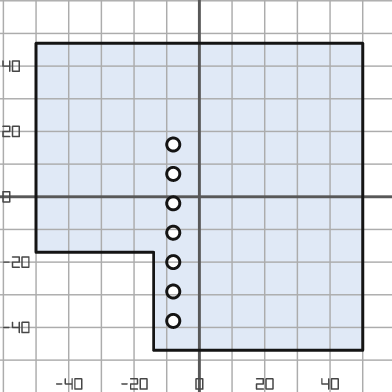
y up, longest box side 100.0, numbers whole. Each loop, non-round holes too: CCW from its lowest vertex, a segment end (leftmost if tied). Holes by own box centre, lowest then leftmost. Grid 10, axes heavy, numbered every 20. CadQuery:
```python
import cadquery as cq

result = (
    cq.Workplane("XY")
    .moveTo(-14.0, -47.0)
    .lineTo(50.0, -47.0)
    .lineTo(50.0, 47.0)
    .lineTo(-50.0, 47.0)
    .lineTo(-50.0, -17.0)
    .lineTo(-14.0, -17.0)
    .close()
    .moveTo(-8.0, -38.0)
    .circle(2.0)
    .moveTo(-8.0, -29.0)
    .circle(2.0)
    .moveTo(-8.0, -20.0)
    .circle(2.0)
    .moveTo(-8.0, -11.0)
    .circle(2.0)
    .moveTo(-8.0, -2.0)
    .circle(2.0)
    .moveTo(-8.0, 7.0)
    .circle(2.0)
    .moveTo(-8.0, 16.0)
    .circle(2.0)
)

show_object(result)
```